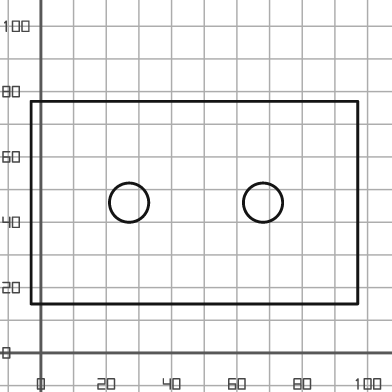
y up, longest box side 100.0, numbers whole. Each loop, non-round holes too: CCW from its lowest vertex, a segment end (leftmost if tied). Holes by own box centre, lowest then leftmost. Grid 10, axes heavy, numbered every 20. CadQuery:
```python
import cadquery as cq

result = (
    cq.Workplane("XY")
    .moveTo(-3.0, 15.0)
    .lineTo(97.0, 15.0)
    .lineTo(97.0, 77.0)
    .lineTo(-3.0, 77.0)
    .close()
    .moveTo(27.0, 46.0)
    .circle(6.0)
    .moveTo(68.0, 46.0)
    .circle(6.0)
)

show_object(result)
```